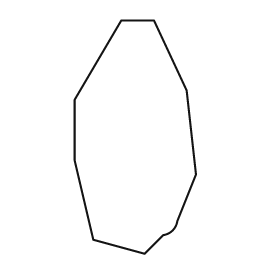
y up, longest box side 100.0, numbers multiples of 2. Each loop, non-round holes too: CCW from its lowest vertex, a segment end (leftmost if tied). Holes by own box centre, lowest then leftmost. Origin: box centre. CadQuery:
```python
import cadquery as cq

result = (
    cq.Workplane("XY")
    .moveTo(4.0, -50.0)
    .lineTo(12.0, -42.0)
    .threePointArc((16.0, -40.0), (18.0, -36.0))
    .lineTo(26.0, -16.0)
    .lineTo(22.0, 20.0)
    .lineTo(8.0, 50.0)
    .lineTo(-6.0, 50.0)
    .lineTo(-26.0, 16.0)
    .lineTo(-26.0, -10.0)
    .lineTo(-18.0, -44.0)
    .close()
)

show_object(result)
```